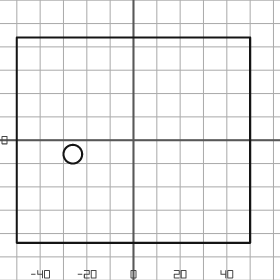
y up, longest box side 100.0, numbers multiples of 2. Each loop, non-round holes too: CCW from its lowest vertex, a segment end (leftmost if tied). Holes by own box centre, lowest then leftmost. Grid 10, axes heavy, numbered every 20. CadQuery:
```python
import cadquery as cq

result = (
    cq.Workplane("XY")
    .moveTo(-50.0, -44.0)
    .lineTo(50.0, -44.0)
    .lineTo(50.0, 44.0)
    .lineTo(-50.0, 44.0)
    .close()
    .moveTo(-26.0, -6.0)
    .circle(4.0)
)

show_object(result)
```